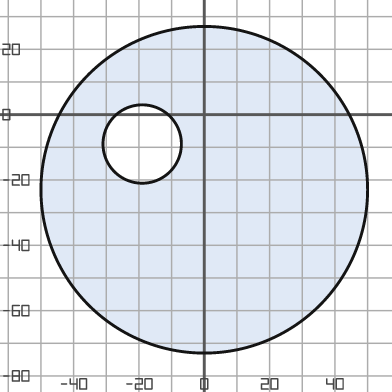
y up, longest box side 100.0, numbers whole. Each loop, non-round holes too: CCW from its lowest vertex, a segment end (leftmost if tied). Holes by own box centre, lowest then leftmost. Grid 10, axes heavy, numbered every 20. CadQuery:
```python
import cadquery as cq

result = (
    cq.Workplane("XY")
    .moveTo(0.0, -23.0)
    .circle(50.0)
    .moveTo(-19.0, -9.0)
    .circle(12.0)
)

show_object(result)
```